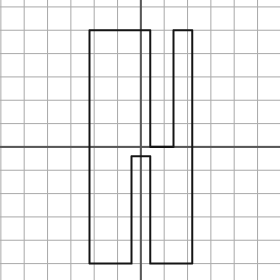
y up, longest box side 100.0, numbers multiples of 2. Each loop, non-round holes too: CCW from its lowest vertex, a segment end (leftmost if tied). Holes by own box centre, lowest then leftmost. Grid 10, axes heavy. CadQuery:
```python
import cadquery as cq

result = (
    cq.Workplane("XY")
    .moveTo(-22.0, -50.0)
    .lineTo(-4.0, -50.0)
    .lineTo(-4.0, -4.0)
    .lineTo(4.0, -4.0)
    .lineTo(4.0, -50.0)
    .lineTo(22.0, -50.0)
    .lineTo(22.0, 50.0)
    .lineTo(14.0, 50.0)
    .lineTo(14.0, 0.0)
    .lineTo(4.0, 0.0)
    .lineTo(4.0, 50.0)
    .lineTo(-22.0, 50.0)
    .close()
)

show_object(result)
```